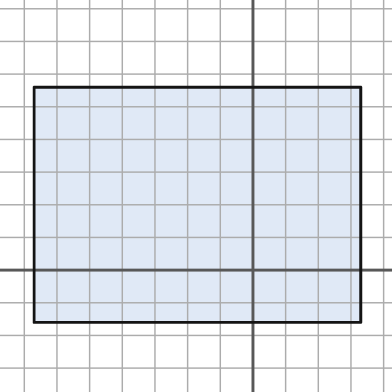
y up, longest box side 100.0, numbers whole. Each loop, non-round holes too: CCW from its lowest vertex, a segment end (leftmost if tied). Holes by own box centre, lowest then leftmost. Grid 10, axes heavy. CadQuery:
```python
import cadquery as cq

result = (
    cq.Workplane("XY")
    .moveTo(-67.0, -16.0)
    .lineTo(33.0, -16.0)
    .lineTo(33.0, 56.0)
    .lineTo(-67.0, 56.0)
    .close()
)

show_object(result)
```